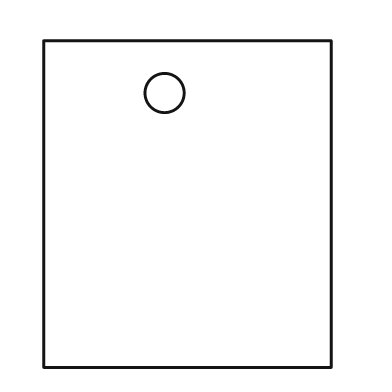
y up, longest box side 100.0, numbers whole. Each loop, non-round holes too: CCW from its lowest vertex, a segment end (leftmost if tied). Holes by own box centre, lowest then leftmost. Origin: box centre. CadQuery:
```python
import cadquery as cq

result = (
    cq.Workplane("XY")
    .moveTo(-44.0, -50.0)
    .lineTo(44.0, -50.0)
    .lineTo(44.0, 50.0)
    .lineTo(-44.0, 50.0)
    .close()
    .moveTo(-7.0, 34.0)
    .circle(6.0)
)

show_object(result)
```